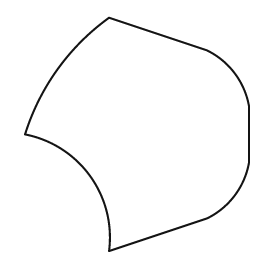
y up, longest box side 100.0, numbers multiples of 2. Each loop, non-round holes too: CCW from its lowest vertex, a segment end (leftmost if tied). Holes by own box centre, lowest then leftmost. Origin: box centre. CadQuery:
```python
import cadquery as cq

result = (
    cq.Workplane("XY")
    .moveTo(-12.0, -50.0)
    .lineTo(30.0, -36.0)
    .threePointArc((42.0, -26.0), (48.0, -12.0))
    .lineTo(48.0, 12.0)
    .threePointArc((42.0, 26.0), (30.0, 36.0))
    .lineTo(-12.0, 50.0)
    .threePointArc((-34.0, 28.0), (-48.0, 0.0))
    .threePointArc((-20.0, -18.0), (-12.0, -50.0))
    .close()
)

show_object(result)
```